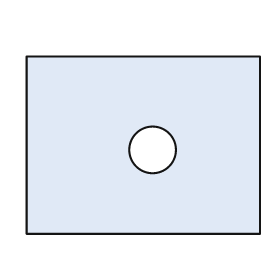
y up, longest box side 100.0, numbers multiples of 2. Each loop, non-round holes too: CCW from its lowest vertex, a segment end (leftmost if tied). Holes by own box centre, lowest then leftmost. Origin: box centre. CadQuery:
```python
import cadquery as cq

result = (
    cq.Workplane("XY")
    .moveTo(-50.0, -38.0)
    .lineTo(50.0, -38.0)
    .lineTo(50.0, 38.0)
    .lineTo(-50.0, 38.0)
    .close()
    .moveTo(4.0, -2.0)
    .circle(10.0)
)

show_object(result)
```